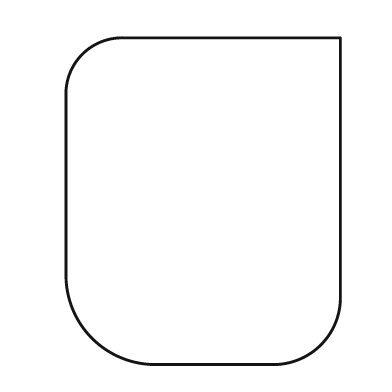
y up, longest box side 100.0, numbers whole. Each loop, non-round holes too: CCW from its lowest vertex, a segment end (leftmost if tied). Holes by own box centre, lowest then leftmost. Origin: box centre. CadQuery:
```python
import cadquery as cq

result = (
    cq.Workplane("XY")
    .moveTo(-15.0, -50.0)
    .lineTo(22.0, -50.0)
    .threePointArc((36.0, -44.0), (42.0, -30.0))
    .lineTo(42.0, 50.0)
    .lineTo(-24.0, 50.0)
    .threePointArc((-37.0, 45.0), (-42.0, 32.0))
    .lineTo(-42.0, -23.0)
    .threePointArc((-34.0, -42.0), (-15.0, -50.0))
    .close()
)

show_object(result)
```